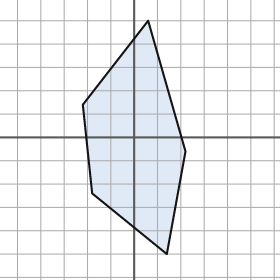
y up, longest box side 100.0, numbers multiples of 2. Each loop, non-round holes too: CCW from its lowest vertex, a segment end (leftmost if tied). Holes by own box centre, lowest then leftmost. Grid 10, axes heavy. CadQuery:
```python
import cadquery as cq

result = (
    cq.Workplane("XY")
    .moveTo(14.0, -50.0)
    .lineTo(22.0, -6.0)
    .lineTo(6.0, 50.0)
    .lineTo(-22.0, 14.0)
    .lineTo(-18.0, -24.0)
    .close()
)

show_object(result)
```